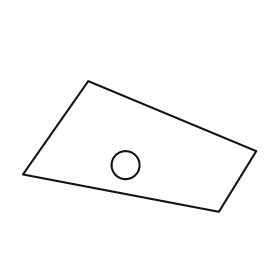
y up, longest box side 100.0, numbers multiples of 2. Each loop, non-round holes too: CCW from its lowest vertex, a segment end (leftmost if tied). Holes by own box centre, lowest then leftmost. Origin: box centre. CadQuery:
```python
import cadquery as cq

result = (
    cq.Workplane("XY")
    .moveTo(34.0, -28.0)
    .lineTo(50.0, -2.0)
    .lineTo(-22.0, 28.0)
    .lineTo(-50.0, -12.0)
    .close()
    .moveTo(-6.0, -8.0)
    .circle(6.0)
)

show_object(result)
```